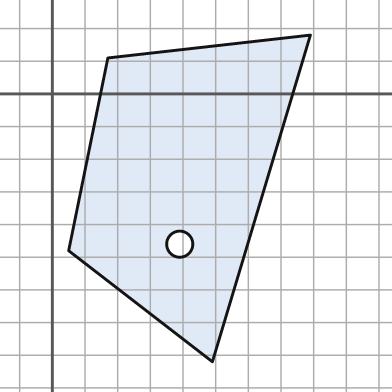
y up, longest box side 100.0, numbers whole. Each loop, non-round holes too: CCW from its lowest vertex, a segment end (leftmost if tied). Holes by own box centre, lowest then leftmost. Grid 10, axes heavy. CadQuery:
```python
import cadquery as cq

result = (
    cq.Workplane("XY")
    .moveTo(49.0, -82.0)
    .lineTo(79.0, 18.0)
    .lineTo(17.0, 11.0)
    .lineTo(5.0, -48.0)
    .close()
    .moveTo(39.0, -46.0)
    .circle(4.0)
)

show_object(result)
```